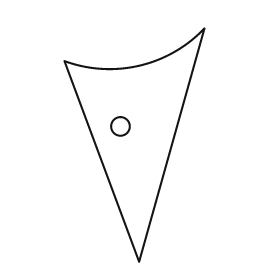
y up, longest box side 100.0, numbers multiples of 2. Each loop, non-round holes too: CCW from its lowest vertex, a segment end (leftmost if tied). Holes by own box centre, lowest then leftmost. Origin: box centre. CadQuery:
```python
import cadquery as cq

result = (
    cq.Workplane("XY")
    .moveTo(2.0, -50.0)
    .lineTo(30.0, 50.0)
    .threePointArc((2.0, 34.0), (-30.0, 36.0))
    .close()
    .moveTo(-6.0, 8.0)
    .circle(4.0)
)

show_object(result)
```